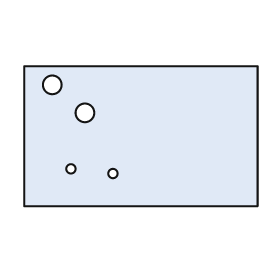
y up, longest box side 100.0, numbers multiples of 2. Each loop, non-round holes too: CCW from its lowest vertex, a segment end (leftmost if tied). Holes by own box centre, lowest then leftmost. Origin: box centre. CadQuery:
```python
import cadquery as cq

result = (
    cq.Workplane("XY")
    .moveTo(-50.0, -30.0)
    .lineTo(50.0, -30.0)
    .lineTo(50.0, 30.0)
    .lineTo(-50.0, 30.0)
    .close()
    .moveTo(-12.0, -16.0)
    .circle(2.0)
    .moveTo(-30.0, -14.0)
    .circle(2.0)
    .moveTo(-24.0, 10.0)
    .circle(4.0)
    .moveTo(-38.0, 22.0)
    .circle(4.0)
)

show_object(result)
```